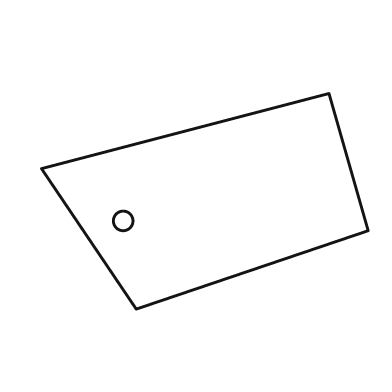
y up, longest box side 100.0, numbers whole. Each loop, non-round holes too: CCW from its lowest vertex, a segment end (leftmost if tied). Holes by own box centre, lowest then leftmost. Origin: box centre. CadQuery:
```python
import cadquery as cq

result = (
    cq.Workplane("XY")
    .moveTo(-21.0, -33.0)
    .lineTo(50.0, -9.0)
    .lineTo(38.0, 33.0)
    .lineTo(-50.0, 10.0)
    .close()
    .moveTo(-25.0, -6.0)
    .circle(3.0)
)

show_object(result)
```